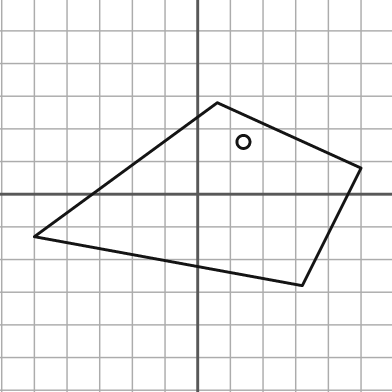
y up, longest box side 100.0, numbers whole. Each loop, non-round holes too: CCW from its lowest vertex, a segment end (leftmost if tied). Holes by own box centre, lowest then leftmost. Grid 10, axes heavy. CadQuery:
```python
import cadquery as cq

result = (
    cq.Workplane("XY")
    .moveTo(32.0, -28.0)
    .lineTo(50.0, 8.0)
    .lineTo(6.0, 28.0)
    .lineTo(-50.0, -13.0)
    .close()
    .moveTo(14.0, 16.0)
    .circle(2.0)
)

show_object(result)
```